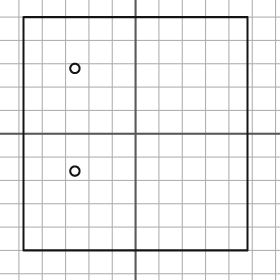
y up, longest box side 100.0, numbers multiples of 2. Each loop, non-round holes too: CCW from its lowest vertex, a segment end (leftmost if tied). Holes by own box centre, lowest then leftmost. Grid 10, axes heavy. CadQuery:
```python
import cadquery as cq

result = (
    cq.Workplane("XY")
    .moveTo(-48.0, -50.0)
    .lineTo(48.0, -50.0)
    .lineTo(48.0, 50.0)
    .lineTo(-48.0, 50.0)
    .close()
    .moveTo(-26.0, -16.0)
    .circle(2.0)
    .moveTo(-26.0, 28.0)
    .circle(2.0)
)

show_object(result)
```